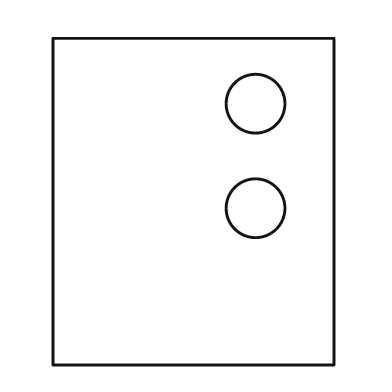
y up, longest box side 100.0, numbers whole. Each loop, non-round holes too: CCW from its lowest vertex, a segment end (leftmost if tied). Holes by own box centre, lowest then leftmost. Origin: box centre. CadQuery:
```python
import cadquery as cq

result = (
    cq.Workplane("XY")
    .moveTo(-43.0, -50.0)
    .lineTo(43.0, -50.0)
    .lineTo(43.0, 50.0)
    .lineTo(-43.0, 50.0)
    .close()
    .moveTo(19.0, -2.0)
    .circle(9.0)
    .moveTo(19.0, 30.0)
    .circle(9.0)
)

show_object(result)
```